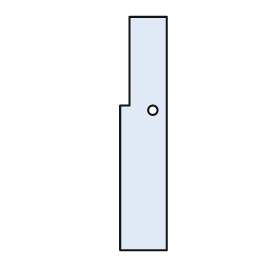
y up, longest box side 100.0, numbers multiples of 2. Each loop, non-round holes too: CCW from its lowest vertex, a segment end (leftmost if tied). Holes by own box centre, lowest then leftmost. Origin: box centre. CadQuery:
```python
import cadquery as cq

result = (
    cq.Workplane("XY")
    .moveTo(-10.0, -50.0)
    .lineTo(10.0, -50.0)
    .lineTo(10.0, 50.0)
    .lineTo(-6.0, 50.0)
    .lineTo(-6.0, 12.0)
    .lineTo(-10.0, 12.0)
    .close()
    .moveTo(4.0, 10.0)
    .circle(2.0)
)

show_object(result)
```